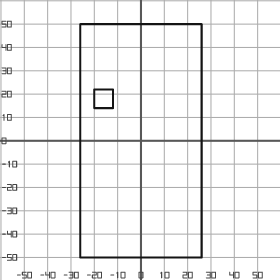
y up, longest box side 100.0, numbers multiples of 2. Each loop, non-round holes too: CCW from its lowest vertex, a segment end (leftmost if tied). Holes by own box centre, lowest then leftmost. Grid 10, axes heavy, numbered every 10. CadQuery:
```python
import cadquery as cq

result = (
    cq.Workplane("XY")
    .moveTo(-26.0, -50.0)
    .lineTo(26.0, -50.0)
    .lineTo(26.0, 50.0)
    .lineTo(-26.0, 50.0)
    .close()
    .moveTo(-20.0, 14.0)
    .lineTo(-12.0, 14.0)
    .lineTo(-12.0, 22.0)
    .lineTo(-20.0, 22.0)
    .close()
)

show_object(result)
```